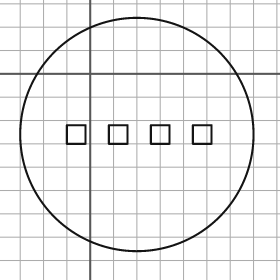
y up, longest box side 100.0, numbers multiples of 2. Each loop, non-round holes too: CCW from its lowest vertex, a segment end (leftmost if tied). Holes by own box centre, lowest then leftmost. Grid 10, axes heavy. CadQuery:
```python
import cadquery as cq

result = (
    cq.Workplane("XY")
    .moveTo(20.0, -26.0)
    .circle(50.0)
    .moveTo(-10.0, -30.0)
    .lineTo(-2.0, -30.0)
    .lineTo(-2.0, -22.0)
    .lineTo(-10.0, -22.0)
    .close()
    .moveTo(8.0, -30.0)
    .lineTo(16.0, -30.0)
    .lineTo(16.0, -22.0)
    .lineTo(8.0, -22.0)
    .close()
    .moveTo(26.0, -30.0)
    .lineTo(34.0, -30.0)
    .lineTo(34.0, -22.0)
    .lineTo(26.0, -22.0)
    .close()
    .moveTo(44.0, -30.0)
    .lineTo(52.0, -30.0)
    .lineTo(52.0, -22.0)
    .lineTo(44.0, -22.0)
    .close()
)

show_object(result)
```